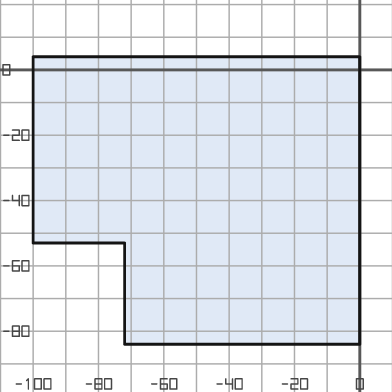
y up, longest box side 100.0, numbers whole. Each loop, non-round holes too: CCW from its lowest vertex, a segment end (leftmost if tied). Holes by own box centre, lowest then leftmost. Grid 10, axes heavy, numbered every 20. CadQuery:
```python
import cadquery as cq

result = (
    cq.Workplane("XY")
    .moveTo(-72.0, -84.0)
    .lineTo(0.0, -84.0)
    .lineTo(0.0, 4.0)
    .lineTo(-100.0, 4.0)
    .lineTo(-100.0, -53.0)
    .lineTo(-72.0, -53.0)
    .close()
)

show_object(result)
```